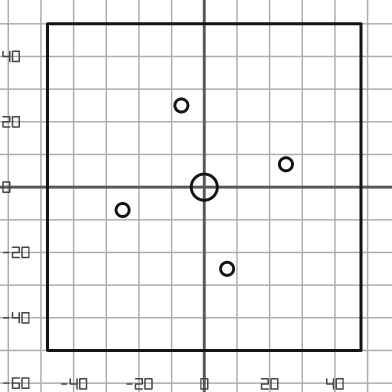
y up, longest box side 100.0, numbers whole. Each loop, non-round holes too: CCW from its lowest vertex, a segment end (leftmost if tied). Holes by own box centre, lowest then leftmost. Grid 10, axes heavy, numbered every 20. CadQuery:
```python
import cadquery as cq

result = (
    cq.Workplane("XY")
    .moveTo(-48.0, -50.0)
    .lineTo(48.0, -50.0)
    .lineTo(48.0, 50.0)
    .lineTo(-48.0, 50.0)
    .close()
    .moveTo(7.0, -25.0)
    .circle(2.0)
    .moveTo(-25.0, -7.0)
    .circle(2.0)
    .moveTo(0.0, 0.0)
    .circle(4.0)
    .moveTo(25.0, 7.0)
    .circle(2.0)
    .moveTo(-7.0, 25.0)
    .circle(2.0)
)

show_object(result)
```